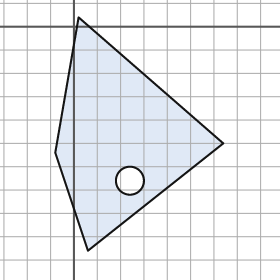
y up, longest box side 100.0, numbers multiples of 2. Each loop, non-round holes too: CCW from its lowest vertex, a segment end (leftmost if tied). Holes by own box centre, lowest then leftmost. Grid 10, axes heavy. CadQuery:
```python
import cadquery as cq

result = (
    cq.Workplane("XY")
    .moveTo(6.0, -96.0)
    .lineTo(64.0, -50.0)
    .lineTo(2.0, 4.0)
    .lineTo(-8.0, -54.0)
    .close()
    .moveTo(24.0, -66.0)
    .circle(6.0)
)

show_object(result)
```